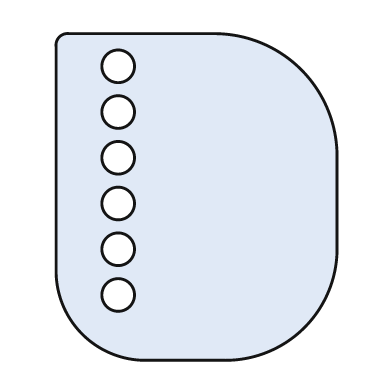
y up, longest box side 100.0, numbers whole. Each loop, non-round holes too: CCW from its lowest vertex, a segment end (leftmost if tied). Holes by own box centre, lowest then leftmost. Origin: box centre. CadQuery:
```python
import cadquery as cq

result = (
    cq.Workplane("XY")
    .moveTo(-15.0, -50.0)
    .lineTo(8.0, -50.0)
    .threePointArc((33.0, -40.0), (43.0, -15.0))
    .lineTo(43.0, 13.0)
    .threePointArc((32.0, 39.0), (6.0, 50.0))
    .lineTo(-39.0, 50.0)
    .threePointArc((-42.0, 49.0), (-43.0, 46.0))
    .lineTo(-43.0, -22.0)
    .threePointArc((-35.0, -42.0), (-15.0, -50.0))
    .close()
    .moveTo(-24.0, -30.0)
    .circle(5.0)
    .moveTo(-24.0, -16.0)
    .circle(5.0)
    .moveTo(-24.0, -2.0)
    .circle(5.0)
    .moveTo(-24.0, 12.0)
    .circle(5.0)
    .moveTo(-24.0, 26.0)
    .circle(5.0)
    .moveTo(-24.0, 40.0)
    .circle(5.0)
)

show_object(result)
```